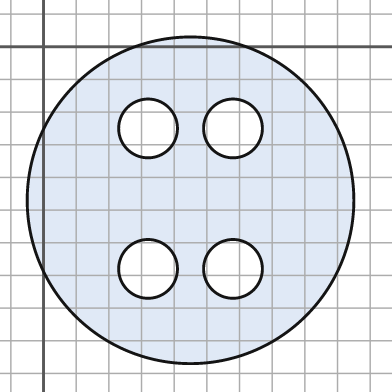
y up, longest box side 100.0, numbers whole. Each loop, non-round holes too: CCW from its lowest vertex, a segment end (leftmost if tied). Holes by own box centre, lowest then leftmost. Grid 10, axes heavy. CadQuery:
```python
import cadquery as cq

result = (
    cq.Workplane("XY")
    .moveTo(45.0, -47.0)
    .circle(50.0)
    .moveTo(32.0, -68.0)
    .circle(9.0)
    .moveTo(58.0, -68.0)
    .circle(9.0)
    .moveTo(32.0, -25.0)
    .circle(9.0)
    .moveTo(58.0, -25.0)
    .circle(9.0)
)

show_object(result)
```